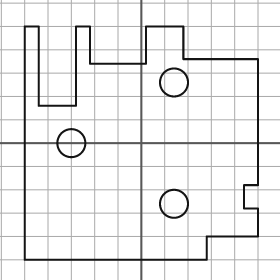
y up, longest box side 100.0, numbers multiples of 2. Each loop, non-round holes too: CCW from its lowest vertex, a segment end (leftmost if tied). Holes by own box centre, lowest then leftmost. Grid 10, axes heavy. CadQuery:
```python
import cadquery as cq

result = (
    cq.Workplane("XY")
    .moveTo(-50.0, -50.0)
    .lineTo(28.0, -50.0)
    .lineTo(28.0, -40.0)
    .lineTo(50.0, -40.0)
    .lineTo(50.0, -28.0)
    .lineTo(44.0, -28.0)
    .lineTo(44.0, -18.0)
    .lineTo(50.0, -18.0)
    .lineTo(50.0, 36.0)
    .lineTo(18.0, 36.0)
    .lineTo(18.0, 50.0)
    .lineTo(2.0, 50.0)
    .lineTo(2.0, 34.0)
    .lineTo(-22.0, 34.0)
    .lineTo(-22.0, 50.0)
    .lineTo(-28.0, 50.0)
    .lineTo(-28.0, 16.0)
    .lineTo(-44.0, 16.0)
    .lineTo(-44.0, 50.0)
    .lineTo(-50.0, 50.0)
    .close()
    .moveTo(14.0, -26.0)
    .circle(6.0)
    .moveTo(-30.0, 0.0)
    .circle(6.0)
    .moveTo(14.0, 26.0)
    .circle(6.0)
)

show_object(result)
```